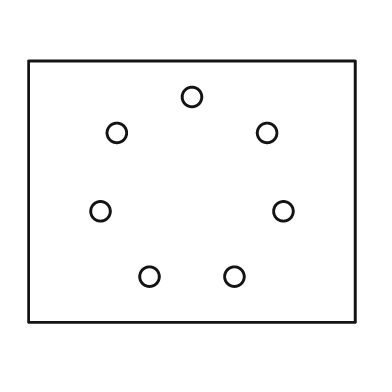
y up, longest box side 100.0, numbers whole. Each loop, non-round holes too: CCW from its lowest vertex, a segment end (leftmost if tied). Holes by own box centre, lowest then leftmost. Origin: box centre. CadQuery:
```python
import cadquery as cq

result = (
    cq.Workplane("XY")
    .moveTo(-50.0, -40.0)
    .lineTo(50.0, -40.0)
    .lineTo(50.0, 40.0)
    .lineTo(-50.0, 40.0)
    .close()
    .moveTo(-13.0, -26.0)
    .circle(3.0)
    .moveTo(13.0, -26.0)
    .circle(3.0)
    .moveTo(-28.0, -6.0)
    .circle(3.0)
    .moveTo(28.0, -6.0)
    .circle(3.0)
    .moveTo(-23.0, 18.0)
    .circle(3.0)
    .moveTo(23.0, 18.0)
    .circle(3.0)
    .moveTo(0.0, 29.0)
    .circle(3.0)
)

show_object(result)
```